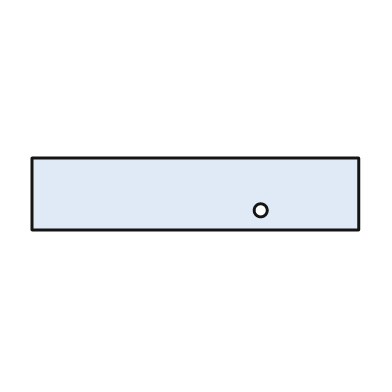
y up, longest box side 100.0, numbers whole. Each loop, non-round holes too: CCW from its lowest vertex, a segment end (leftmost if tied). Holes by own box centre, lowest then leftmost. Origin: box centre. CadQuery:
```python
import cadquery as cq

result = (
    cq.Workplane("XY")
    .moveTo(-50.0, -11.0)
    .lineTo(50.0, -11.0)
    .lineTo(50.0, 11.0)
    .lineTo(-50.0, 11.0)
    .close()
    .moveTo(20.0, -5.0)
    .circle(2.0)
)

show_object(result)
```